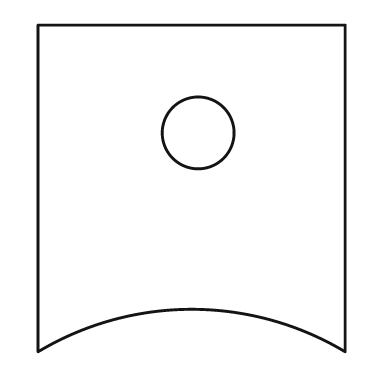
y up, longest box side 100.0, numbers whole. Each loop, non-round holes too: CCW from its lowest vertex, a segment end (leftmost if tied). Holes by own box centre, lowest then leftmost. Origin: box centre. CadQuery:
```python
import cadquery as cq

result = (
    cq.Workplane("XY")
    .moveTo(-47.0, -50.0)
    .threePointArc((0.0, -37.0), (47.0, -50.0))
    .lineTo(47.0, 50.0)
    .lineTo(-47.0, 50.0)
    .close()
    .moveTo(2.0, 17.0)
    .circle(11.0)
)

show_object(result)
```